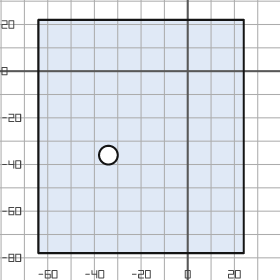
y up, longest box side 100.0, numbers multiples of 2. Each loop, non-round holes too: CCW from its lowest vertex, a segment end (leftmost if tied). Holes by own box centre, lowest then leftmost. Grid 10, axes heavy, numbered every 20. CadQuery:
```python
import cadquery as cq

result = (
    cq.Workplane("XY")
    .moveTo(-64.0, -78.0)
    .lineTo(24.0, -78.0)
    .lineTo(24.0, 22.0)
    .lineTo(-64.0, 22.0)
    .close()
    .moveTo(-34.0, -36.0)
    .circle(4.0)
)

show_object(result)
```